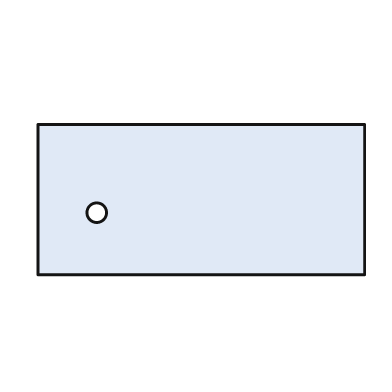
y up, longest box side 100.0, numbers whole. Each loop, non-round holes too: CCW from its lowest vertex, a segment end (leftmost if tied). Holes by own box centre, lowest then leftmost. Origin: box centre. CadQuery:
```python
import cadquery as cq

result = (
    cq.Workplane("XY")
    .moveTo(-50.0, -23.0)
    .lineTo(50.0, -23.0)
    .lineTo(50.0, 23.0)
    .lineTo(-50.0, 23.0)
    .close()
    .moveTo(-32.0, -4.0)
    .circle(3.0)
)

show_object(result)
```